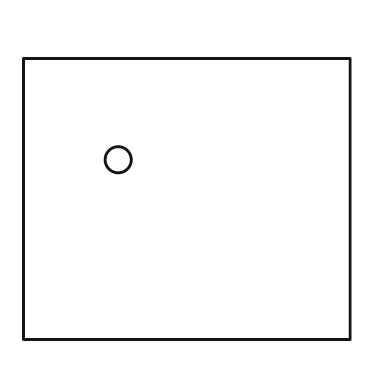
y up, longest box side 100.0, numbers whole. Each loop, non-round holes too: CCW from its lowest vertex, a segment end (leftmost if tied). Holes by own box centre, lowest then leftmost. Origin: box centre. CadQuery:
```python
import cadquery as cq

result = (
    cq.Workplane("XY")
    .moveTo(-50.0, -43.0)
    .lineTo(50.0, -43.0)
    .lineTo(50.0, 43.0)
    .lineTo(-50.0, 43.0)
    .close()
    .moveTo(-21.0, 12.0)
    .circle(4.0)
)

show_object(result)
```